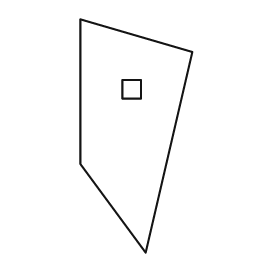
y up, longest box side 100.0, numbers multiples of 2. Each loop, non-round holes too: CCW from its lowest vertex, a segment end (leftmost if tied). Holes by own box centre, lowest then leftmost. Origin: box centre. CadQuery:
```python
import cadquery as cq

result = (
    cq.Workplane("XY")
    .moveTo(4.0, -50.0)
    .lineTo(24.0, 36.0)
    .lineTo(-24.0, 50.0)
    .lineTo(-24.0, -12.0)
    .close()
    .moveTo(-6.0, 16.0)
    .lineTo(2.0, 16.0)
    .lineTo(2.0, 24.0)
    .lineTo(-6.0, 24.0)
    .close()
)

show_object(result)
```